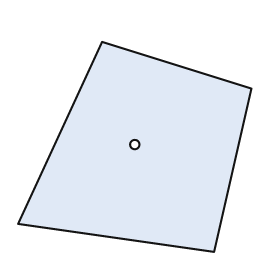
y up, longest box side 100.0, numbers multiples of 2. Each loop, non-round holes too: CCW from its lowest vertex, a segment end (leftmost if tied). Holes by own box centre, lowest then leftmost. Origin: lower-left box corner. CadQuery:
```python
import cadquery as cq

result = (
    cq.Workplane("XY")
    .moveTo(84.0, 0.0)
    .lineTo(100.0, 70.0)
    .lineTo(36.0, 90.0)
    .lineTo(0.0, 12.0)
    .close()
    .moveTo(50.0, 46.0)
    .circle(2.0)
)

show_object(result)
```